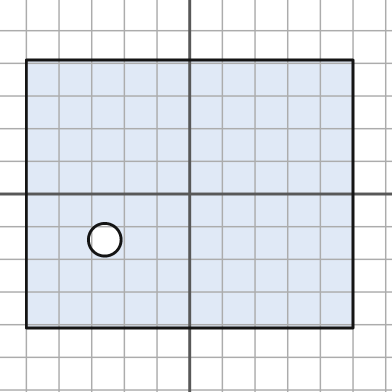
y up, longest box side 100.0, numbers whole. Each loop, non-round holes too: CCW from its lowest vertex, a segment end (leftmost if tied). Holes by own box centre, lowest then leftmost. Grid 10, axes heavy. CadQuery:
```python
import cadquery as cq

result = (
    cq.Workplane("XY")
    .moveTo(-50.0, -41.0)
    .lineTo(50.0, -41.0)
    .lineTo(50.0, 41.0)
    .lineTo(-50.0, 41.0)
    .close()
    .moveTo(-26.0, -14.0)
    .circle(5.0)
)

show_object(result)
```